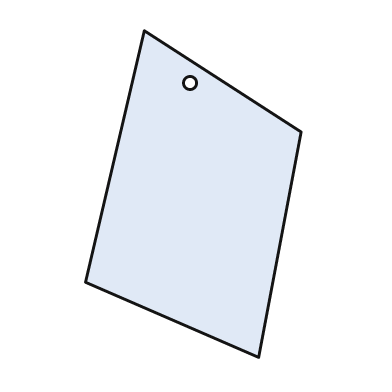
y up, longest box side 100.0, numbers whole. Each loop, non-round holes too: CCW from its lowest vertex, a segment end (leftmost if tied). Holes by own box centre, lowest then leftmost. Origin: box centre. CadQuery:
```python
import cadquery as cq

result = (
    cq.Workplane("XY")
    .moveTo(20.0, -50.0)
    .lineTo(33.0, 19.0)
    .lineTo(-15.0, 50.0)
    .lineTo(-33.0, -27.0)
    .close()
    .moveTo(-1.0, 34.0)
    .circle(2.0)
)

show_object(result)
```